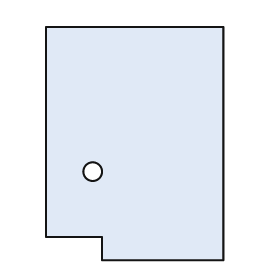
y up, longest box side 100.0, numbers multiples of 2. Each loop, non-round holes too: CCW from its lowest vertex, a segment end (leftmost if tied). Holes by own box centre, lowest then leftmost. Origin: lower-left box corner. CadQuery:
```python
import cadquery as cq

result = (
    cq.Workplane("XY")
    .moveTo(24.0, 0.0)
    .lineTo(76.0, 0.0)
    .lineTo(76.0, 100.0)
    .lineTo(0.0, 100.0)
    .lineTo(0.0, 10.0)
    .lineTo(24.0, 10.0)
    .close()
    .moveTo(20.0, 38.0)
    .circle(4.0)
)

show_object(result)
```